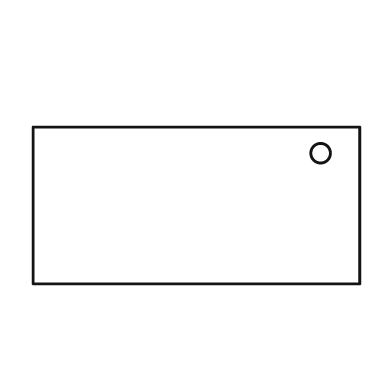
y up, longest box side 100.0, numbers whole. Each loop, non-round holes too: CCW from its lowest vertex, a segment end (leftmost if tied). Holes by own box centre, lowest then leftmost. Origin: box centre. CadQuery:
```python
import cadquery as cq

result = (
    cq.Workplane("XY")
    .moveTo(-50.0, -24.0)
    .lineTo(50.0, -24.0)
    .lineTo(50.0, 24.0)
    .lineTo(-50.0, 24.0)
    .close()
    .moveTo(38.0, 16.0)
    .circle(3.0)
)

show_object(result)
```